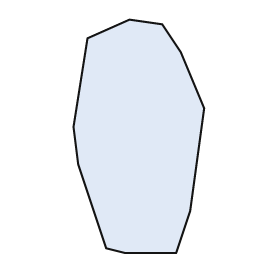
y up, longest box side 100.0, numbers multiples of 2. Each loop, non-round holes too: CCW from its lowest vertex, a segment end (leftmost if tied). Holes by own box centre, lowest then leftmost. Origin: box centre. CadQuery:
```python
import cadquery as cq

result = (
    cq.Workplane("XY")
    .moveTo(-6.0, -50.0)
    .lineTo(16.0, -50.0)
    .lineTo(22.0, -32.0)
    .lineTo(28.0, 12.0)
    .lineTo(18.0, 36.0)
    .lineTo(10.0, 48.0)
    .lineTo(-4.0, 50.0)
    .lineTo(-22.0, 42.0)
    .lineTo(-28.0, 4.0)
    .lineTo(-26.0, -12.0)
    .lineTo(-14.0, -48.0)
    .close()
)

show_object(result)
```